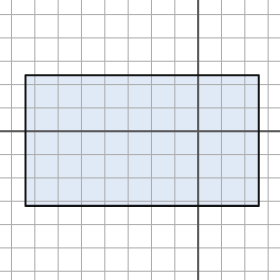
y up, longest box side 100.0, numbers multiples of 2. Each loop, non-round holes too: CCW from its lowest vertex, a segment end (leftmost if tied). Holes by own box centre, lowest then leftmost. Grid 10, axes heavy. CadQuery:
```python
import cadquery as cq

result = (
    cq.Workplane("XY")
    .moveTo(-74.0, -32.0)
    .lineTo(26.0, -32.0)
    .lineTo(26.0, 24.0)
    .lineTo(-74.0, 24.0)
    .close()
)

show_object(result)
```